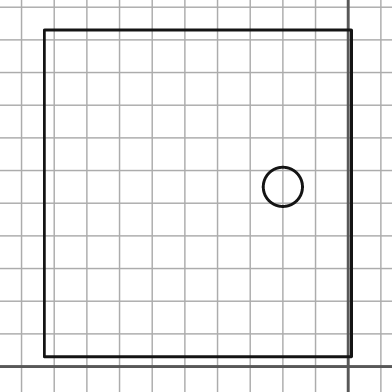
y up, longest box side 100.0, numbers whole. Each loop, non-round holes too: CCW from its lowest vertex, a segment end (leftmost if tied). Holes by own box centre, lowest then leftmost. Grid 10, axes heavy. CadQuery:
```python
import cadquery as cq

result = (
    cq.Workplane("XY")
    .moveTo(-93.0, 3.0)
    .lineTo(1.0, 3.0)
    .lineTo(1.0, 103.0)
    .lineTo(-93.0, 103.0)
    .close()
    .moveTo(-20.0, 55.0)
    .circle(6.0)
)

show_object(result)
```